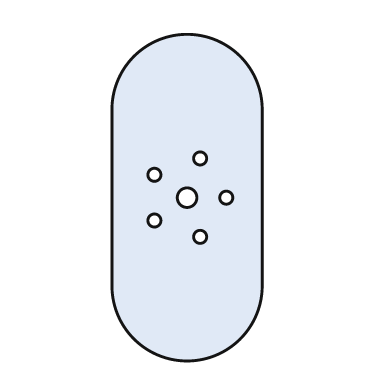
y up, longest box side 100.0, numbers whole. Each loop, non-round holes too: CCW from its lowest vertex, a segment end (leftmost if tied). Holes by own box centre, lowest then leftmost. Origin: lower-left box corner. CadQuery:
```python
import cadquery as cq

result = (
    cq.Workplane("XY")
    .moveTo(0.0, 23.0)
    .threePointArc((23.0, 0.0), (46.0, 23.0))
    .lineTo(46.0, 77.0)
    .threePointArc((23.0, 100.0), (0.0, 77.0))
    .close()
    .moveTo(27.0, 38.0)
    .circle(2.0)
    .moveTo(13.0, 43.0)
    .circle(2.0)
    .moveTo(23.0, 50.0)
    .circle(3.0)
    .moveTo(35.0, 50.0)
    .circle(2.0)
    .moveTo(13.0, 57.0)
    .circle(2.0)
    .moveTo(27.0, 62.0)
    .circle(2.0)
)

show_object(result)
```